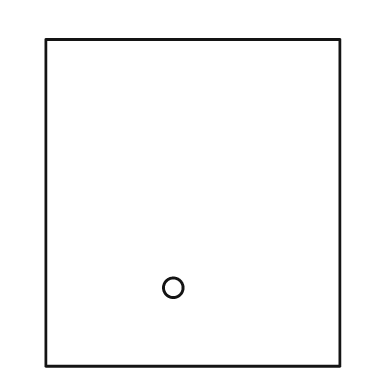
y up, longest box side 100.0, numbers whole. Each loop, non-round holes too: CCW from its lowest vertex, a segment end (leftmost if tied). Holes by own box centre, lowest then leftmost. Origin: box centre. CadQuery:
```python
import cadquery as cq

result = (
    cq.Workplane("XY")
    .moveTo(-45.0, -50.0)
    .lineTo(45.0, -50.0)
    .lineTo(45.0, 50.0)
    .lineTo(-45.0, 50.0)
    .close()
    .moveTo(-6.0, -26.0)
    .circle(3.0)
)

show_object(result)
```